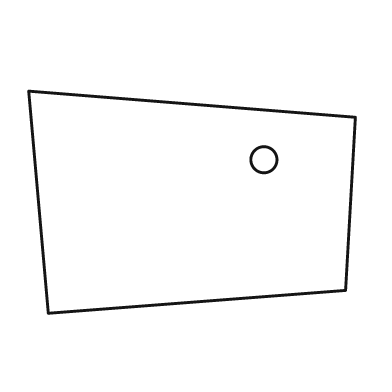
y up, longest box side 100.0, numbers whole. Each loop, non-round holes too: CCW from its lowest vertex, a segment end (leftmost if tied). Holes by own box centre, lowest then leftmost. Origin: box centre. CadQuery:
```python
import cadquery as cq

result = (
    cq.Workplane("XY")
    .moveTo(-44.0, -34.0)
    .lineTo(47.0, -27.0)
    .lineTo(50.0, 26.0)
    .lineTo(-50.0, 34.0)
    .close()
    .moveTo(22.0, 13.0)
    .circle(4.0)
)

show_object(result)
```